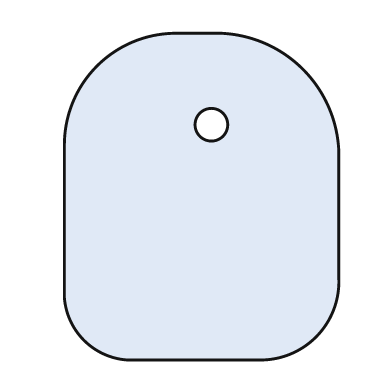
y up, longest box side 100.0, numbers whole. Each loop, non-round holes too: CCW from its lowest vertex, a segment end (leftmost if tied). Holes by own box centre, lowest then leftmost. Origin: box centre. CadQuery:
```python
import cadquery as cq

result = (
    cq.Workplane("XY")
    .moveTo(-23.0, -50.0)
    .lineTo(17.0, -50.0)
    .threePointArc((35.0, -43.0), (42.0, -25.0))
    .lineTo(42.0, 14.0)
    .threePointArc((31.0, 39.0), (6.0, 50.0))
    .lineTo(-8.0, 50.0)
    .threePointArc((-32.0, 40.0), (-42.0, 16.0))
    .lineTo(-42.0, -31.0)
    .threePointArc((-36.0, -44.0), (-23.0, -50.0))
    .close()
    .moveTo(3.0, 22.0)
    .circle(5.0)
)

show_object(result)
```